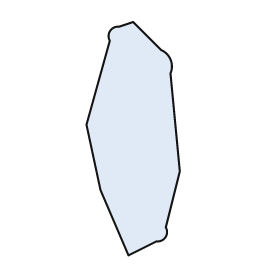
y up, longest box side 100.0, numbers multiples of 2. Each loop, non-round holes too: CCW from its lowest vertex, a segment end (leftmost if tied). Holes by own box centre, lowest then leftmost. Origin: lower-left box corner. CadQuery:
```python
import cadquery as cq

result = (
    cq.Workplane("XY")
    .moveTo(18.0, 0.0)
    .lineTo(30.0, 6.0)
    .threePointArc((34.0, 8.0), (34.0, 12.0))
    .lineTo(40.0, 36.0)
    .lineTo(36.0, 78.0)
    .threePointArc((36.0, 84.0), (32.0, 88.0))
    .lineTo(20.0, 100.0)
    .lineTo(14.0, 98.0)
    .threePointArc((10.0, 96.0), (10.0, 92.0))
    .lineTo(0.0, 56.0)
    .lineTo(6.0, 28.0)
    .close()
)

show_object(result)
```